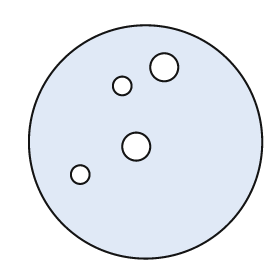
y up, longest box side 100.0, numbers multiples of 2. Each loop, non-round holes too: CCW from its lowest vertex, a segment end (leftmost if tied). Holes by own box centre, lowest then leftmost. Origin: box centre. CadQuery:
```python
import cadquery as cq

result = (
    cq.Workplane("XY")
    .moveTo(0.0, 0.0)
    .circle(50.0)
    .moveTo(-28.0, -14.0)
    .circle(4.0)
    .moveTo(-4.0, -2.0)
    .circle(6.0)
    .moveTo(-10.0, 24.0)
    .circle(4.0)
    .moveTo(8.0, 32.0)
    .circle(6.0)
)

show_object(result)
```